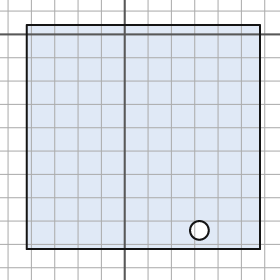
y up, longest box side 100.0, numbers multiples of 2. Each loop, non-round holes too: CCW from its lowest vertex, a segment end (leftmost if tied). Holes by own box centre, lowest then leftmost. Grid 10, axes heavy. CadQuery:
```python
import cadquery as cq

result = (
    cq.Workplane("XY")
    .moveTo(-42.0, -92.0)
    .lineTo(58.0, -92.0)
    .lineTo(58.0, 4.0)
    .lineTo(-42.0, 4.0)
    .close()
    .moveTo(32.0, -84.0)
    .circle(4.0)
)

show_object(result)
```